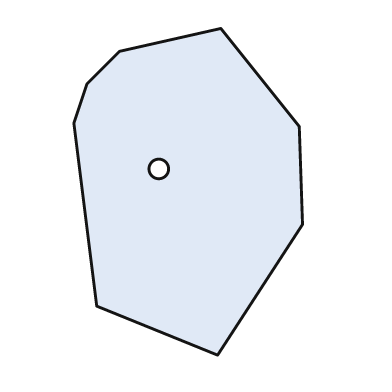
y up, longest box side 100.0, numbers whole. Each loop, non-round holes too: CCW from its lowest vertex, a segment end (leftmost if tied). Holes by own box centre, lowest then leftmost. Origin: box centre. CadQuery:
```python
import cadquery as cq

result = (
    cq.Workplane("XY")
    .moveTo(9.0, -50.0)
    .lineTo(35.0, -10.0)
    .lineTo(34.0, 20.0)
    .lineTo(10.0, 50.0)
    .lineTo(-21.0, 43.0)
    .lineTo(-31.0, 33.0)
    .lineTo(-35.0, 21.0)
    .lineTo(-28.0, -35.0)
    .close()
    .moveTo(-9.0, 7.0)
    .circle(3.0)
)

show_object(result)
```